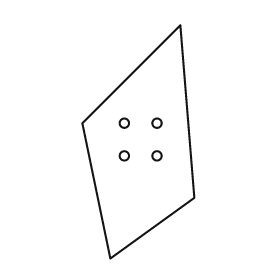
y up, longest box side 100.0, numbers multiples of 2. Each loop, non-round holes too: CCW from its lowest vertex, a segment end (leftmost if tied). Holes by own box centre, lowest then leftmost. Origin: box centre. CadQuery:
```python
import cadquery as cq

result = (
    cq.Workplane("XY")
    .moveTo(-12.0, -50.0)
    .lineTo(24.0, -24.0)
    .lineTo(18.0, 50.0)
    .lineTo(-24.0, 8.0)
    .close()
    .moveTo(-6.0, -6.0)
    .circle(2.0)
    .moveTo(8.0, -6.0)
    .circle(2.0)
    .moveTo(-6.0, 8.0)
    .circle(2.0)
    .moveTo(8.0, 8.0)
    .circle(2.0)
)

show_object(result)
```